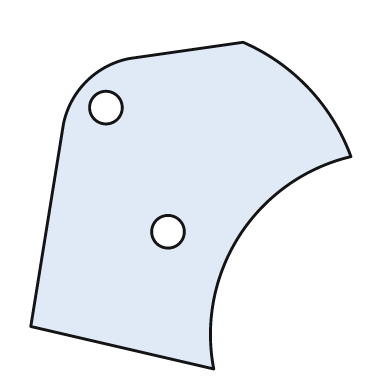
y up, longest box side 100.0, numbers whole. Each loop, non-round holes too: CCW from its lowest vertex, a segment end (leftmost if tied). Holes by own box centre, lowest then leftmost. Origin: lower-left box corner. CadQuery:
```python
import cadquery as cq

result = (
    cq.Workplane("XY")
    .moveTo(56.0, 0.0)
    .threePointArc((64.0, 41.0), (98.0, 65.0))
    .threePointArc((85.0, 86.0), (65.0, 100.0))
    .lineTo(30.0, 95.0)
    .threePointArc((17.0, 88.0), (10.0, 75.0))
    .lineTo(0.0, 13.0)
    .close()
    .moveTo(42.0, 42.0)
    .circle(5.0)
    .moveTo(23.0, 80.0)
    .circle(5.0)
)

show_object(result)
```